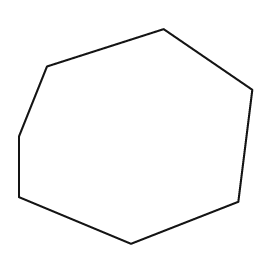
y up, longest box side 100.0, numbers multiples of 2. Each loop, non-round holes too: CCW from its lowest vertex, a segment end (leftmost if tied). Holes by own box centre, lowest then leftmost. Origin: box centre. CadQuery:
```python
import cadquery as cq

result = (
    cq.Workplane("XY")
    .moveTo(-2.0, -46.0)
    .lineTo(44.0, -28.0)
    .lineTo(50.0, 20.0)
    .lineTo(12.0, 46.0)
    .lineTo(-38.0, 30.0)
    .lineTo(-50.0, 0.0)
    .lineTo(-50.0, -26.0)
    .close()
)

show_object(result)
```